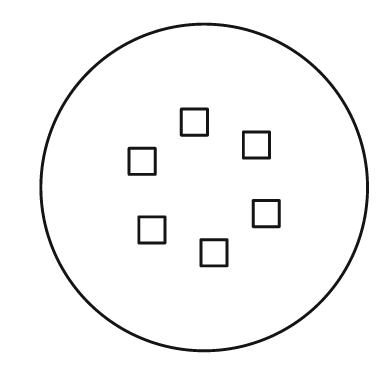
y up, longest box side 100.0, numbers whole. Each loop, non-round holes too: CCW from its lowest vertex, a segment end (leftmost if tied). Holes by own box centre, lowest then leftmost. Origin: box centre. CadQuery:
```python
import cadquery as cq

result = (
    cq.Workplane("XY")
    .moveTo(0.0, 0.0)
    .circle(50.0)
    .moveTo(-1.0, -24.0)
    .lineTo(7.0, -24.0)
    .lineTo(7.0, -16.0)
    .lineTo(-1.0, -16.0)
    .close()
    .moveTo(-20.0, -17.0)
    .lineTo(-12.0, -17.0)
    .lineTo(-12.0, -9.0)
    .lineTo(-20.0, -9.0)
    .close()
    .moveTo(15.0, -12.0)
    .lineTo(23.0, -12.0)
    .lineTo(23.0, -4.0)
    .lineTo(15.0, -4.0)
    .close()
    .moveTo(-23.0, 4.0)
    .lineTo(-15.0, 4.0)
    .lineTo(-15.0, 12.0)
    .lineTo(-23.0, 12.0)
    .close()
    .moveTo(12.0, 9.0)
    .lineTo(20.0, 9.0)
    .lineTo(20.0, 17.0)
    .lineTo(12.0, 17.0)
    .close()
    .moveTo(-7.0, 16.0)
    .lineTo(1.0, 16.0)
    .lineTo(1.0, 24.0)
    .lineTo(-7.0, 24.0)
    .close()
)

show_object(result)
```